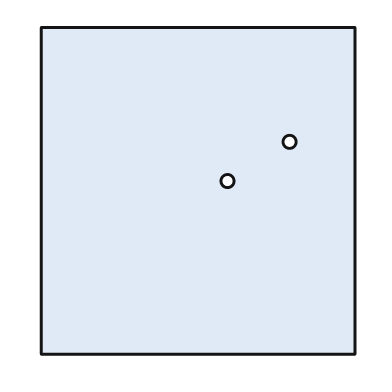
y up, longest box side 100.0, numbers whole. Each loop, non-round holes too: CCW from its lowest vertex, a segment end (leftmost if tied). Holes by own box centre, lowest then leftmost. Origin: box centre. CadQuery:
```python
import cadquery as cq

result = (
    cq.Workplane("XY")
    .moveTo(-48.0, -50.0)
    .lineTo(48.0, -50.0)
    .lineTo(48.0, 50.0)
    .lineTo(-48.0, 50.0)
    .close()
    .moveTo(9.0, 3.0)
    .circle(2.0)
    .moveTo(28.0, 15.0)
    .circle(2.0)
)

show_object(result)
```